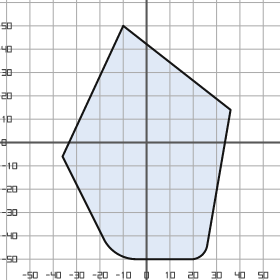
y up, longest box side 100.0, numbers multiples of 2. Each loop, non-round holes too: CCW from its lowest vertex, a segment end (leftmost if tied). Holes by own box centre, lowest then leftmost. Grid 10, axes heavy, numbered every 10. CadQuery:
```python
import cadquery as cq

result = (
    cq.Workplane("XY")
    .moveTo(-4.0, -50.0)
    .lineTo(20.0, -50.0)
    .threePointArc((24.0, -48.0), (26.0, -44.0))
    .lineTo(36.0, 14.0)
    .lineTo(-10.0, 50.0)
    .lineTo(-36.0, -6.0)
    .lineTo(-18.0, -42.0)
    .threePointArc((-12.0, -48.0), (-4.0, -50.0))
    .close()
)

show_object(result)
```